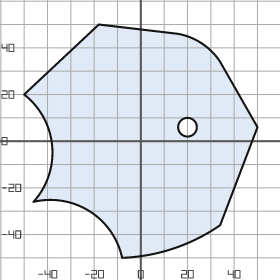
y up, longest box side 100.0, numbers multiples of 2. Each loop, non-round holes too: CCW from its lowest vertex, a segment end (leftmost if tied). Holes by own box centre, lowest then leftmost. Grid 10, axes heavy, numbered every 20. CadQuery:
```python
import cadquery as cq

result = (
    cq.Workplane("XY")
    .moveTo(-8.0, -50.0)
    .threePointArc((14.0, -46.0), (34.0, -36.0))
    .lineTo(50.0, 6.0)
    .lineTo(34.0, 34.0)
    .threePointArc((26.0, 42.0), (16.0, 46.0))
    .lineTo(-18.0, 50.0)
    .lineTo(-50.0, 20.0)
    .threePointArc((-38.0, -2.0), (-46.0, -26.0))
    .threePointArc((-22.0, -30.0), (-8.0, -50.0))
    .close()
    .moveTo(20.0, 6.0)
    .circle(4.0)
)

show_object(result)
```